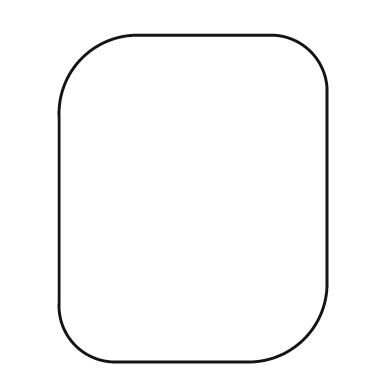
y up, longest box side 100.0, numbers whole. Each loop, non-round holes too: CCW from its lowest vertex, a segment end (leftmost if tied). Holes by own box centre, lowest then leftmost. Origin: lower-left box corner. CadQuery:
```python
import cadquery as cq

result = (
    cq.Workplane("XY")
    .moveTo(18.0, 0.0)
    .lineTo(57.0, 0.0)
    .threePointArc((75.0, 7.0), (82.0, 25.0))
    .lineTo(82.0, 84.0)
    .threePointArc((77.0, 95.0), (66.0, 100.0))
    .lineTo(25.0, 100.0)
    .threePointArc((7.0, 93.0), (0.0, 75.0))
    .lineTo(0.0, 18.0)
    .threePointArc((5.0, 5.0), (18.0, 0.0))
    .close()
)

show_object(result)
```